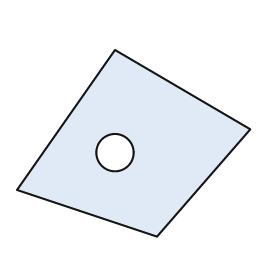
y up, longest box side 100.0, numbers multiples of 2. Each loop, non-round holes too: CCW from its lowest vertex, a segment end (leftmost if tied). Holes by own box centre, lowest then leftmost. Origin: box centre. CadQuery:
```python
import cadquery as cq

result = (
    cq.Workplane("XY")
    .moveTo(10.0, -40.0)
    .lineTo(50.0, 6.0)
    .lineTo(-8.0, 40.0)
    .lineTo(-50.0, -20.0)
    .close()
    .moveTo(-8.0, -4.0)
    .circle(8.0)
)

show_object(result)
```